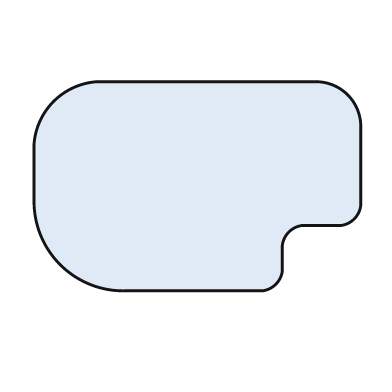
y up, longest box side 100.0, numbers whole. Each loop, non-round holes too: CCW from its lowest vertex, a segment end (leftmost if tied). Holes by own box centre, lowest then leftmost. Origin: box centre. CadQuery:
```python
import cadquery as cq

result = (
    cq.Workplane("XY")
    .moveTo(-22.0, -32.0)
    .lineTo(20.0, -32.0)
    .threePointArc((24.0, -30.0), (26.0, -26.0))
    .lineTo(26.0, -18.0)
    .threePointArc((28.0, -14.0), (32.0, -12.0))
    .lineTo(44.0, -12.0)
    .threePointArc((48.0, -10.0), (50.0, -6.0))
    .lineTo(50.0, 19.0)
    .threePointArc((46.0, 28.0), (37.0, 32.0))
    .lineTo(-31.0, 32.0)
    .threePointArc((-44.0, 26.0), (-50.0, 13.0))
    .lineTo(-50.0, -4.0)
    .threePointArc((-42.0, -24.0), (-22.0, -32.0))
    .close()
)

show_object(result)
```